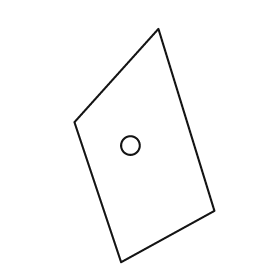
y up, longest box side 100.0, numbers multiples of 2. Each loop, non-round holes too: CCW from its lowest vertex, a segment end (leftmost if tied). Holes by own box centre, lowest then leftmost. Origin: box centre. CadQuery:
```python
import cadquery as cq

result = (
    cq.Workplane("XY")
    .moveTo(-10.0, -50.0)
    .lineTo(30.0, -28.0)
    .lineTo(6.0, 50.0)
    .lineTo(-30.0, 10.0)
    .close()
    .moveTo(-6.0, 0.0)
    .circle(4.0)
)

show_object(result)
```